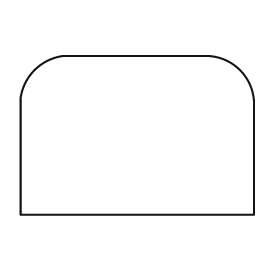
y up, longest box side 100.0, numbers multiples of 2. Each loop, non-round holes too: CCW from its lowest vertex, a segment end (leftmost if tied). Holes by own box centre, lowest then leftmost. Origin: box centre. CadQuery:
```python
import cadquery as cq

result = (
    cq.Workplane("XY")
    .moveTo(-50.0, -34.0)
    .lineTo(50.0, -34.0)
    .lineTo(50.0, 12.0)
    .threePointArc((44.0, 28.0), (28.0, 34.0))
    .lineTo(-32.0, 34.0)
    .threePointArc((-44.0, 28.0), (-50.0, 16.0))
    .close()
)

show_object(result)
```